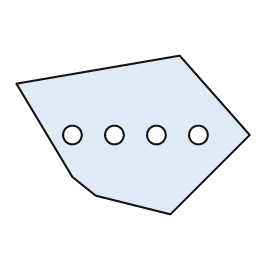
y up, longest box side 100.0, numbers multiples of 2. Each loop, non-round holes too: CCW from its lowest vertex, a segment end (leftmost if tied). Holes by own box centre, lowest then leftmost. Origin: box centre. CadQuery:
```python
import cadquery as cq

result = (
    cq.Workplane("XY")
    .moveTo(16.0, -34.0)
    .lineTo(50.0, 0.0)
    .lineTo(20.0, 34.0)
    .lineTo(-50.0, 22.0)
    .lineTo(-26.0, -18.0)
    .lineTo(-16.0, -26.0)
    .close()
    .moveTo(-26.0, 0.0)
    .circle(4.0)
    .moveTo(-8.0, 0.0)
    .circle(4.0)
    .moveTo(10.0, 0.0)
    .circle(4.0)
    .moveTo(28.0, 0.0)
    .circle(4.0)
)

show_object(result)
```